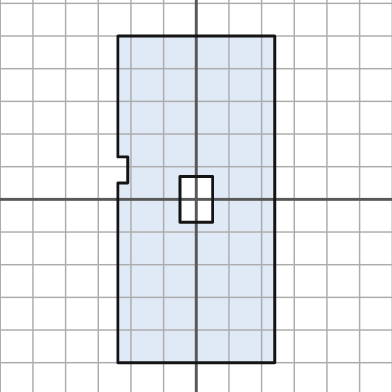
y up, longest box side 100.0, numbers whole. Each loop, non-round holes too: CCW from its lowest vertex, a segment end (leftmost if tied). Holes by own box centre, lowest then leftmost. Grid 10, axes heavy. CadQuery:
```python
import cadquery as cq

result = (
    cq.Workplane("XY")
    .moveTo(-24.0, -50.0)
    .lineTo(24.0, -50.0)
    .lineTo(24.0, 50.0)
    .lineTo(-24.0, 50.0)
    .lineTo(-24.0, 13.0)
    .lineTo(-21.0, 13.0)
    .lineTo(-21.0, 5.0)
    .lineTo(-24.0, 5.0)
    .close()
    .moveTo(-5.0, -7.0)
    .lineTo(5.0, -7.0)
    .lineTo(5.0, 7.0)
    .lineTo(-5.0, 7.0)
    .close()
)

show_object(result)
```